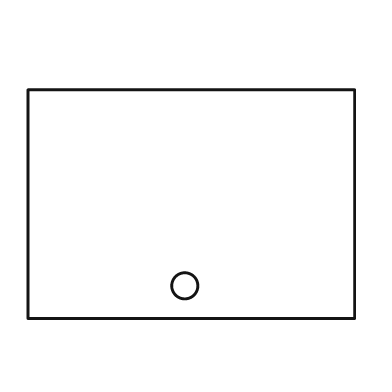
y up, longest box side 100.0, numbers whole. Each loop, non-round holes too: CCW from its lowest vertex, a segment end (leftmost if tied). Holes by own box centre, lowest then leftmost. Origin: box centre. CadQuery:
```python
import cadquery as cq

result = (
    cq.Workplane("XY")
    .moveTo(-50.0, -35.0)
    .lineTo(50.0, -35.0)
    .lineTo(50.0, 35.0)
    .lineTo(-50.0, 35.0)
    .close()
    .moveTo(-2.0, -25.0)
    .circle(4.0)
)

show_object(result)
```